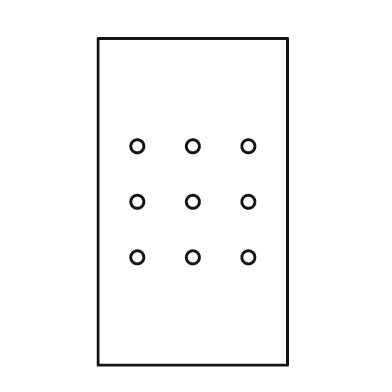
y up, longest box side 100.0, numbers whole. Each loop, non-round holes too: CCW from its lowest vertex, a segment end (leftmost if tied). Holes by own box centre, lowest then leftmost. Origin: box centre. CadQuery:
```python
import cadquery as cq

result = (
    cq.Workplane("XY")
    .moveTo(-29.0, -50.0)
    .lineTo(29.0, -50.0)
    .lineTo(29.0, 50.0)
    .lineTo(-29.0, 50.0)
    .close()
    .moveTo(-17.0, -17.0)
    .circle(2.0)
    .moveTo(0.0, -17.0)
    .circle(2.0)
    .moveTo(17.0, -17.0)
    .circle(2.0)
    .moveTo(-17.0, 0.0)
    .circle(2.0)
    .moveTo(0.0, 0.0)
    .circle(2.0)
    .moveTo(17.0, 0.0)
    .circle(2.0)
    .moveTo(-17.0, 17.0)
    .circle(2.0)
    .moveTo(0.0, 17.0)
    .circle(2.0)
    .moveTo(17.0, 17.0)
    .circle(2.0)
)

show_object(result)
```